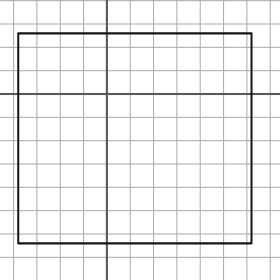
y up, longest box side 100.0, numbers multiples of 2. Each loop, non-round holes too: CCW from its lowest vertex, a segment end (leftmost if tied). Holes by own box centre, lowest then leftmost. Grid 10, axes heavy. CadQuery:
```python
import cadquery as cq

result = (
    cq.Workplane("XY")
    .moveTo(-38.0, -64.0)
    .lineTo(62.0, -64.0)
    .lineTo(62.0, 26.0)
    .lineTo(-38.0, 26.0)
    .close()
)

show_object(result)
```